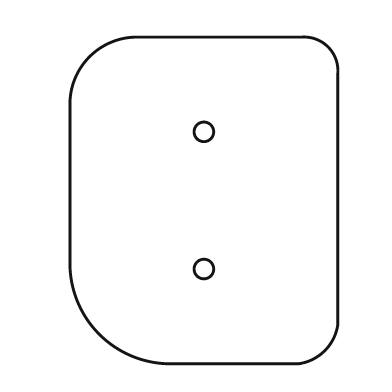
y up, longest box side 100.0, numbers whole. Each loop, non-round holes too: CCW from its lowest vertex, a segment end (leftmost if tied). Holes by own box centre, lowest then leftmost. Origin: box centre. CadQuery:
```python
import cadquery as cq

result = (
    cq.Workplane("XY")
    .moveTo(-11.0, -50.0)
    .lineTo(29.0, -50.0)
    .threePointArc((37.0, -46.0), (41.0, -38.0))
    .lineTo(41.0, 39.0)
    .threePointArc((38.0, 47.0), (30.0, 50.0))
    .lineTo(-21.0, 50.0)
    .threePointArc((-35.0, 44.0), (-41.0, 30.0))
    .lineTo(-41.0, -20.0)
    .threePointArc((-32.0, -41.0), (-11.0, -50.0))
    .close()
    .moveTo(0.0, -21.0)
    .circle(3.0)
    .moveTo(0.0, 21.0)
    .circle(3.0)
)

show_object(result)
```